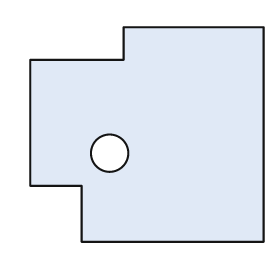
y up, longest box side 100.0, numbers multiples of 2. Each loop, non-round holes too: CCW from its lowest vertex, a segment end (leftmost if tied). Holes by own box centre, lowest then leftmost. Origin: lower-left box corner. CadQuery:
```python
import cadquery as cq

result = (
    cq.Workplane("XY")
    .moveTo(22.0, 0.0)
    .lineTo(100.0, 0.0)
    .lineTo(100.0, 92.0)
    .lineTo(40.0, 92.0)
    .lineTo(40.0, 78.0)
    .lineTo(0.0, 78.0)
    .lineTo(0.0, 24.0)
    .lineTo(22.0, 24.0)
    .close()
    .moveTo(34.0, 38.0)
    .circle(8.0)
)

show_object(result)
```